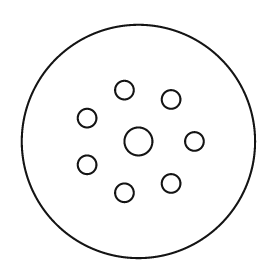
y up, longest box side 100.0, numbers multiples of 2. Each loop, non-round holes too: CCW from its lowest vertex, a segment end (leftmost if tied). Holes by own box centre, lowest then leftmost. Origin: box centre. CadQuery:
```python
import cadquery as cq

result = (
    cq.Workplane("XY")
    .moveTo(0.0, 0.0)
    .circle(50.0)
    .moveTo(-6.0, -22.0)
    .circle(4.0)
    .moveTo(14.0, -18.0)
    .circle(4.0)
    .moveTo(-22.0, -10.0)
    .circle(4.0)
    .moveTo(0.0, 0.0)
    .circle(6.0)
    .moveTo(24.0, 0.0)
    .circle(4.0)
    .moveTo(-22.0, 10.0)
    .circle(4.0)
    .moveTo(14.0, 18.0)
    .circle(4.0)
    .moveTo(-6.0, 22.0)
    .circle(4.0)
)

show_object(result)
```